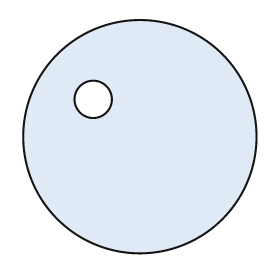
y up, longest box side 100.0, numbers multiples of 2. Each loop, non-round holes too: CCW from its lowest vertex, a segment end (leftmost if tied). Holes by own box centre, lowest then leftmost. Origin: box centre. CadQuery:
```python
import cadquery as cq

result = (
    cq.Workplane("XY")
    .moveTo(0.0, 0.0)
    .circle(50.0)
    .moveTo(-20.0, 16.0)
    .circle(8.0)
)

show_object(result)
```